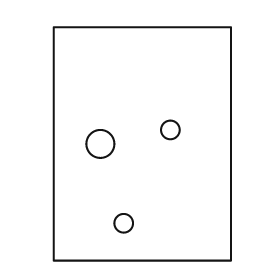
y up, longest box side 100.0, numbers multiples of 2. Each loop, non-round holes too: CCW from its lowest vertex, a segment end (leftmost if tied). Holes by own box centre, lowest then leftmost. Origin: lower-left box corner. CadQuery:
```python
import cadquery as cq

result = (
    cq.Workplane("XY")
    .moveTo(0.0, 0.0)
    .lineTo(76.0, 0.0)
    .lineTo(76.0, 100.0)
    .lineTo(0.0, 100.0)
    .close()
    .moveTo(30.0, 16.0)
    .circle(4.0)
    .moveTo(20.0, 50.0)
    .circle(6.0)
    .moveTo(50.0, 56.0)
    .circle(4.0)
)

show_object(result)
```